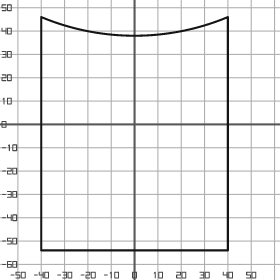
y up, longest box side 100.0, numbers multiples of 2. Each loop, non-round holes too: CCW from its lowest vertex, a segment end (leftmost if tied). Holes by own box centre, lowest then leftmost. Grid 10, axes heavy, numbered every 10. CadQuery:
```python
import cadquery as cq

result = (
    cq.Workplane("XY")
    .moveTo(-40.0, -54.0)
    .lineTo(40.0, -54.0)
    .lineTo(40.0, 46.0)
    .threePointArc((0.0, 38.0), (-40.0, 46.0))
    .close()
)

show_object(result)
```